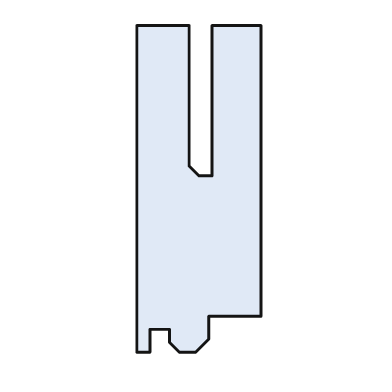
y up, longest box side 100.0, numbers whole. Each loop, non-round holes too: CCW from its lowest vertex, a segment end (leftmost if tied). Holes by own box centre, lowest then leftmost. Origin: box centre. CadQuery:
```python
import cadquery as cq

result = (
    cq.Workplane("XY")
    .moveTo(-19.0, -50.0)
    .lineTo(-15.0, -50.0)
    .lineTo(-15.0, -43.0)
    .lineTo(-9.0, -43.0)
    .lineTo(-9.0, -47.0)
    .lineTo(-6.0, -50.0)
    .lineTo(-1.0, -50.0)
    .lineTo(3.0, -46.0)
    .lineTo(3.0, -39.0)
    .lineTo(19.0, -39.0)
    .lineTo(19.0, 50.0)
    .lineTo(4.0, 50.0)
    .lineTo(4.0, 4.0)
    .lineTo(0.0, 4.0)
    .lineTo(-3.0, 7.0)
    .lineTo(-3.0, 50.0)
    .lineTo(-19.0, 50.0)
    .close()
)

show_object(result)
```